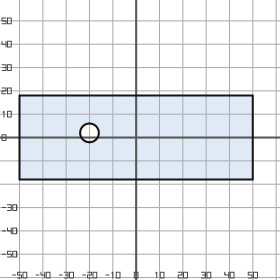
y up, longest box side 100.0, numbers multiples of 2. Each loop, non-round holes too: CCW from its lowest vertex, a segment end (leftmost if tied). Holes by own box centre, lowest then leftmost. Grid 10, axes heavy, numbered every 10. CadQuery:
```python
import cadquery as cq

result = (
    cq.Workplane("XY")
    .moveTo(-50.0, -18.0)
    .lineTo(50.0, -18.0)
    .lineTo(50.0, 18.0)
    .lineTo(-50.0, 18.0)
    .close()
    .moveTo(-20.0, 2.0)
    .circle(4.0)
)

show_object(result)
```